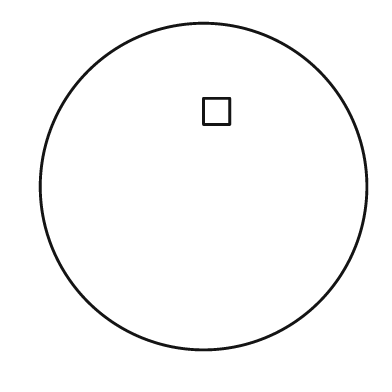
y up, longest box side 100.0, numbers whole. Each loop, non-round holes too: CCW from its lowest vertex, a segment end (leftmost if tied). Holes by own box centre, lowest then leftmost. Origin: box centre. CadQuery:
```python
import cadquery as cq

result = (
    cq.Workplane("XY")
    .moveTo(0.0, 0.0)
    .circle(50.0)
    .moveTo(0.0, 19.0)
    .lineTo(8.0, 19.0)
    .lineTo(8.0, 27.0)
    .lineTo(0.0, 27.0)
    .close()
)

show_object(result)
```